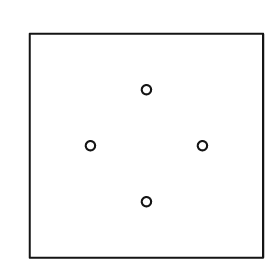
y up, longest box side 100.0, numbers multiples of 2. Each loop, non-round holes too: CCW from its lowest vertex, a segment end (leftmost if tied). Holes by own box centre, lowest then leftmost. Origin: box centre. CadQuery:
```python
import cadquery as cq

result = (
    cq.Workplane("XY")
    .moveTo(-50.0, -48.0)
    .lineTo(50.0, -48.0)
    .lineTo(50.0, 48.0)
    .lineTo(-50.0, 48.0)
    .close()
    .moveTo(0.0, -24.0)
    .circle(2.0)
    .moveTo(-24.0, 0.0)
    .circle(2.0)
    .moveTo(24.0, 0.0)
    .circle(2.0)
    .moveTo(0.0, 24.0)
    .circle(2.0)
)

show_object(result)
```